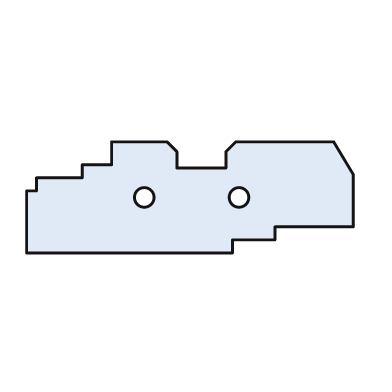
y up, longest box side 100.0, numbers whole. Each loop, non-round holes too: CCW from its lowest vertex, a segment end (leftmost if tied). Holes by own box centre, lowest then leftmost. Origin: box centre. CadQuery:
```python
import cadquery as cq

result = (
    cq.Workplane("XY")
    .moveTo(-50.0, -17.0)
    .lineTo(13.0, -17.0)
    .lineTo(13.0, -13.0)
    .lineTo(26.0, -13.0)
    .lineTo(26.0, -9.0)
    .lineTo(50.0, -9.0)
    .lineTo(50.0, 7.0)
    .lineTo(44.0, 17.0)
    .lineTo(14.0, 17.0)
    .lineTo(11.0, 14.0)
    .lineTo(11.0, 9.0)
    .lineTo(-4.0, 9.0)
    .lineTo(-4.0, 14.0)
    .lineTo(-7.0, 17.0)
    .lineTo(-24.0, 17.0)
    .lineTo(-24.0, 10.0)
    .lineTo(-33.0, 10.0)
    .lineTo(-33.0, 6.0)
    .lineTo(-47.0, 6.0)
    .lineTo(-47.0, 2.0)
    .lineTo(-50.0, 2.0)
    .close()
    .moveTo(-14.0, 0.0)
    .circle(3.0)
    .moveTo(15.0, 0.0)
    .circle(3.0)
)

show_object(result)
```